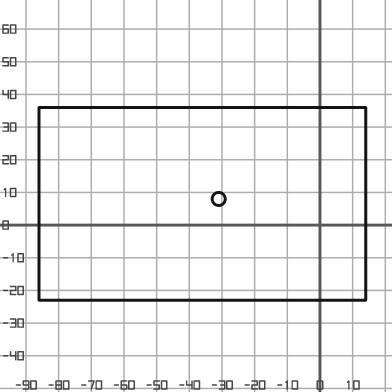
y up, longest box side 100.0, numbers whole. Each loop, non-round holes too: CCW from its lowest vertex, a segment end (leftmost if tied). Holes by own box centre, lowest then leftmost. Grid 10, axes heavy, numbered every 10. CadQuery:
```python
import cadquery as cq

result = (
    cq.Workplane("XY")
    .moveTo(-86.0, -23.0)
    .lineTo(14.0, -23.0)
    .lineTo(14.0, 36.0)
    .lineTo(-86.0, 36.0)
    .close()
    .moveTo(-31.0, 8.0)
    .circle(2.0)
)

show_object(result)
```